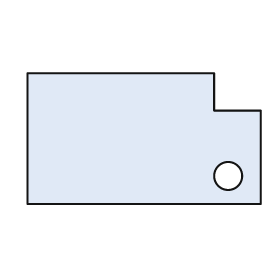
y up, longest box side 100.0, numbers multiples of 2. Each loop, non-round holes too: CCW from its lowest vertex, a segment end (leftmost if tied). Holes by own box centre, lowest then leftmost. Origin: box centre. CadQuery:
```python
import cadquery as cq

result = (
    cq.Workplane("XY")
    .moveTo(-50.0, -28.0)
    .lineTo(50.0, -28.0)
    .lineTo(50.0, 12.0)
    .lineTo(30.0, 12.0)
    .lineTo(30.0, 28.0)
    .lineTo(-50.0, 28.0)
    .close()
    .moveTo(36.0, -16.0)
    .circle(6.0)
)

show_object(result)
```